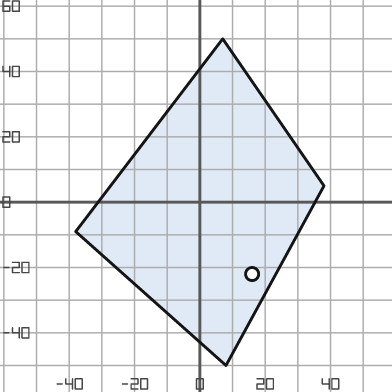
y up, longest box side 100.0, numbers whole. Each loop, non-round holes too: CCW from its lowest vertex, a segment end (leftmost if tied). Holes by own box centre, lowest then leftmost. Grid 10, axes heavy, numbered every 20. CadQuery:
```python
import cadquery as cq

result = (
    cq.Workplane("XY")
    .moveTo(8.0, -50.0)
    .lineTo(38.0, 5.0)
    .lineTo(7.0, 50.0)
    .lineTo(-38.0, -9.0)
    .close()
    .moveTo(16.0, -22.0)
    .circle(2.0)
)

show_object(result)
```